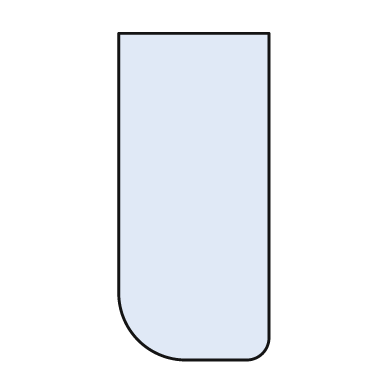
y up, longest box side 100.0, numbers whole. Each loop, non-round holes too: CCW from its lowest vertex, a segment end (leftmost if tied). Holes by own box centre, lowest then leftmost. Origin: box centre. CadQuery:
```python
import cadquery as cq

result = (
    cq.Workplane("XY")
    .moveTo(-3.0, -50.0)
    .lineTo(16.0, -50.0)
    .threePointArc((21.0, -48.0), (23.0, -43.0))
    .lineTo(23.0, 50.0)
    .lineTo(-23.0, 50.0)
    .lineTo(-23.0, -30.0)
    .threePointArc((-17.0, -44.0), (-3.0, -50.0))
    .close()
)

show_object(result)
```